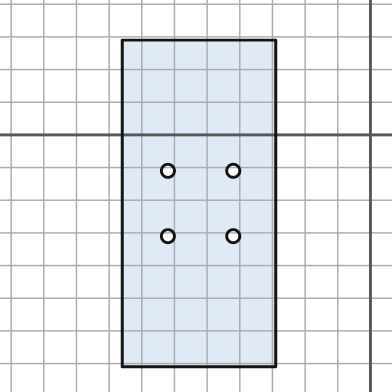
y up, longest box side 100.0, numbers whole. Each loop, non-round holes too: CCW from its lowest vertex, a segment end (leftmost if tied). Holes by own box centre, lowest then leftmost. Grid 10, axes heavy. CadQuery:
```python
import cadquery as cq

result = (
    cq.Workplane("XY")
    .moveTo(-76.0, -71.0)
    .lineTo(-29.0, -71.0)
    .lineTo(-29.0, 29.0)
    .lineTo(-76.0, 29.0)
    .close()
    .moveTo(-62.0, -31.0)
    .circle(2.0)
    .moveTo(-42.0, -31.0)
    .circle(2.0)
    .moveTo(-62.0, -11.0)
    .circle(2.0)
    .moveTo(-42.0, -11.0)
    .circle(2.0)
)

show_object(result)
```